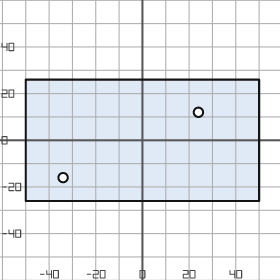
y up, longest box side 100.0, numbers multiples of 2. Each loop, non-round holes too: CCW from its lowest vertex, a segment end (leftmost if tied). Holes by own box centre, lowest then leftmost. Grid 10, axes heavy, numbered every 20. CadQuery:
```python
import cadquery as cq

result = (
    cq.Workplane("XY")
    .moveTo(-50.0, -26.0)
    .lineTo(50.0, -26.0)
    .lineTo(50.0, 26.0)
    .lineTo(-50.0, 26.0)
    .close()
    .moveTo(-34.0, -16.0)
    .circle(2.0)
    .moveTo(24.0, 12.0)
    .circle(2.0)
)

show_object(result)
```